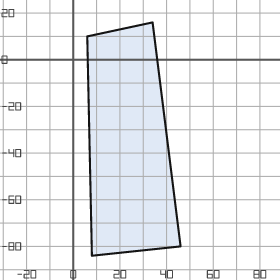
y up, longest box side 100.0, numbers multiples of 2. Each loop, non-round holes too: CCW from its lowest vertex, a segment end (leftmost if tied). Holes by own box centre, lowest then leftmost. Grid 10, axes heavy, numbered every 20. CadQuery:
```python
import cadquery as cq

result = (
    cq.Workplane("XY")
    .moveTo(8.0, -84.0)
    .lineTo(46.0, -80.0)
    .lineTo(34.0, 16.0)
    .lineTo(6.0, 10.0)
    .close()
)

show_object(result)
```